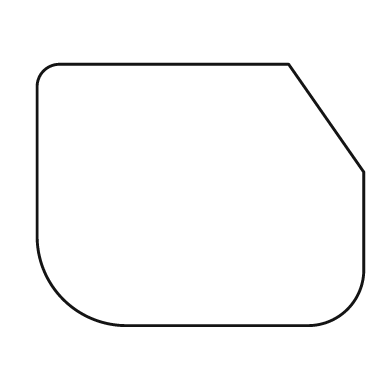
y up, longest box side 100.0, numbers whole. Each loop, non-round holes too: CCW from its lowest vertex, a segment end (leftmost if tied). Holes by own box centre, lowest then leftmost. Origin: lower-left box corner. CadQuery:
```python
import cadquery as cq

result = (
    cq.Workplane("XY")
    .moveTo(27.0, 0.0)
    .lineTo(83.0, 0.0)
    .threePointArc((95.0, 5.0), (100.0, 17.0))
    .lineTo(100.0, 47.0)
    .lineTo(77.0, 80.0)
    .lineTo(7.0, 80.0)
    .threePointArc((2.0, 78.0), (0.0, 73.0))
    .lineTo(0.0, 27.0)
    .threePointArc((8.0, 8.0), (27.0, 0.0))
    .close()
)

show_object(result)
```